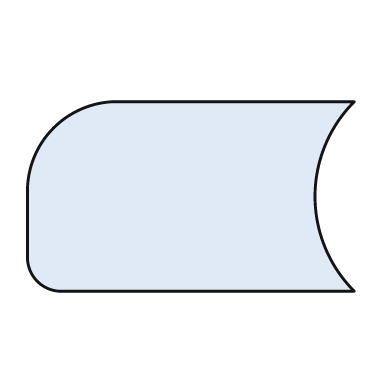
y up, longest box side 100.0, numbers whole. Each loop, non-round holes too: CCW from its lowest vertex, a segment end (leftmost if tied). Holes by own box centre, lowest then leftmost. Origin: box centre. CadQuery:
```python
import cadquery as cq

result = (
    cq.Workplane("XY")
    .moveTo(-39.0, -29.0)
    .lineTo(50.0, -29.0)
    .threePointArc((38.0, 0.0), (50.0, 29.0))
    .lineTo(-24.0, 29.0)
    .threePointArc((-42.0, 21.0), (-50.0, 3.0))
    .lineTo(-50.0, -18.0)
    .threePointArc((-47.0, -26.0), (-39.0, -29.0))
    .close()
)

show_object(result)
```